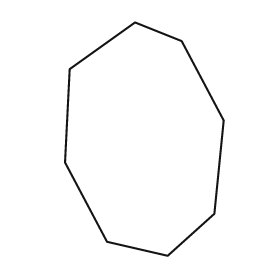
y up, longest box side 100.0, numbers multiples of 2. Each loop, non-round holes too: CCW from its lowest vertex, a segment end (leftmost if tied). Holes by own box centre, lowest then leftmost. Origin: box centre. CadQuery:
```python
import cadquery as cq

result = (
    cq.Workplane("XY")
    .moveTo(10.0, -50.0)
    .lineTo(30.0, -32.0)
    .lineTo(34.0, 8.0)
    .lineTo(16.0, 42.0)
    .lineTo(-4.0, 50.0)
    .lineTo(-32.0, 30.0)
    .lineTo(-34.0, -10.0)
    .lineTo(-16.0, -44.0)
    .close()
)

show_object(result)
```